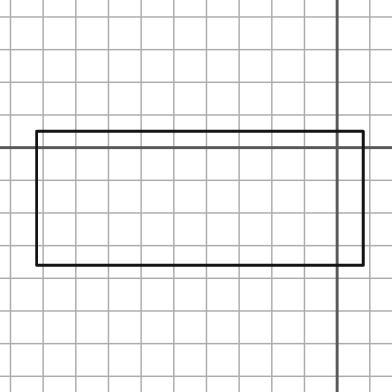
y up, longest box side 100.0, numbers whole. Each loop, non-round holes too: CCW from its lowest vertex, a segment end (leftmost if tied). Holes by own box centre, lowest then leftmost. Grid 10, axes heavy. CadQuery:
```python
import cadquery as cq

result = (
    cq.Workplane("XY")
    .moveTo(-92.0, -36.0)
    .lineTo(8.0, -36.0)
    .lineTo(8.0, 5.0)
    .lineTo(-92.0, 5.0)
    .close()
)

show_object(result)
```